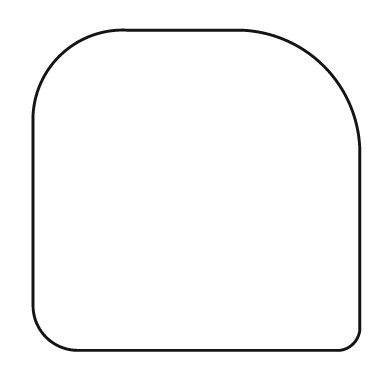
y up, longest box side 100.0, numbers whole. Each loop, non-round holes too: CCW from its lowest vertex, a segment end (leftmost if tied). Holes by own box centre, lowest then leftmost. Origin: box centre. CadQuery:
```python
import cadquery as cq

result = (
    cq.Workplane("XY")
    .moveTo(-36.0, -49.0)
    .lineTo(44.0, -49.0)
    .threePointArc((48.0, -47.0), (50.0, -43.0))
    .lineTo(50.0, 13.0)
    .threePointArc((39.0, 38.0), (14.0, 49.0))
    .lineTo(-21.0, 49.0)
    .threePointArc((-42.0, 41.0), (-50.0, 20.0))
    .lineTo(-50.0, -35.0)
    .threePointArc((-46.0, -45.0), (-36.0, -49.0))
    .close()
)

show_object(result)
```